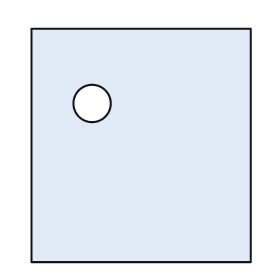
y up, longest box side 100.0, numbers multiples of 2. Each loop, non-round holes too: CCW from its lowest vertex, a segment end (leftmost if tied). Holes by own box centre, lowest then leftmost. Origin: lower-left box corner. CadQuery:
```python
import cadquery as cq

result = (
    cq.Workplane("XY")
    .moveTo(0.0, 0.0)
    .lineTo(94.0, 0.0)
    .lineTo(94.0, 100.0)
    .lineTo(0.0, 100.0)
    .close()
    .moveTo(26.0, 68.0)
    .circle(8.0)
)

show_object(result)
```